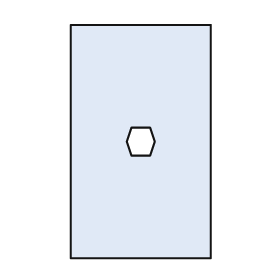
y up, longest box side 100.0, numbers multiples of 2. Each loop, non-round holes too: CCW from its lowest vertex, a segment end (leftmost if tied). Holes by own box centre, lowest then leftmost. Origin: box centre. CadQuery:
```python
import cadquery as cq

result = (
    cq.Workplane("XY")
    .moveTo(-30.0, -50.0)
    .lineTo(30.0, -50.0)
    .lineTo(30.0, 50.0)
    .lineTo(-30.0, 50.0)
    .close()
    .moveTo(-4.0, -6.0)
    .lineTo(4.0, -6.0)
    .lineTo(6.0, 0.0)
    .lineTo(4.0, 6.0)
    .lineTo(-4.0, 6.0)
    .lineTo(-6.0, 0.0)
    .close()
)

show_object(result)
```